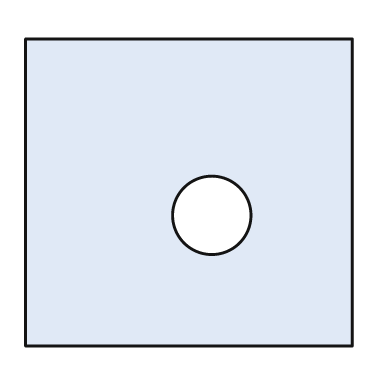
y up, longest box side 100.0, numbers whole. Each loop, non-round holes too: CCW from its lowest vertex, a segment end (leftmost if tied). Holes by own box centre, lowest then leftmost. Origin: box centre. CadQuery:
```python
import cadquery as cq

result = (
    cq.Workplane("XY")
    .moveTo(-50.0, -47.0)
    .lineTo(50.0, -47.0)
    .lineTo(50.0, 47.0)
    .lineTo(-50.0, 47.0)
    .close()
    .moveTo(7.0, -7.0)
    .circle(12.0)
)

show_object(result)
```